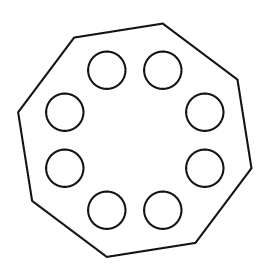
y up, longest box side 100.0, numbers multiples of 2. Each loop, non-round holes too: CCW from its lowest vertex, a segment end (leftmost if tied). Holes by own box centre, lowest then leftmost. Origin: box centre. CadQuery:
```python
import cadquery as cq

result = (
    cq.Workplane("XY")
    .moveTo(-12.0, -50.0)
    .lineTo(26.0, -44.0)
    .lineTo(50.0, -12.0)
    .lineTo(44.0, 26.0)
    .lineTo(12.0, 50.0)
    .lineTo(-26.0, 44.0)
    .lineTo(-50.0, 12.0)
    .lineTo(-44.0, -26.0)
    .close()
    .moveTo(-12.0, -30.0)
    .circle(8.0)
    .moveTo(12.0, -30.0)
    .circle(8.0)
    .moveTo(-30.0, -12.0)
    .circle(8.0)
    .moveTo(30.0, -12.0)
    .circle(8.0)
    .moveTo(-30.0, 12.0)
    .circle(8.0)
    .moveTo(30.0, 12.0)
    .circle(8.0)
    .moveTo(-12.0, 30.0)
    .circle(8.0)
    .moveTo(12.0, 30.0)
    .circle(8.0)
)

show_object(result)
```